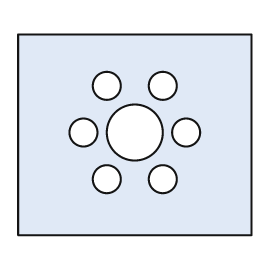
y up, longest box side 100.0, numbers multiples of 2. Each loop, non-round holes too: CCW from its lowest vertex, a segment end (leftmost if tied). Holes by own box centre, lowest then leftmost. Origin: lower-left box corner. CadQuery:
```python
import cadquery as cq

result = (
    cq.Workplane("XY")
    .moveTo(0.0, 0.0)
    .lineTo(100.0, 0.0)
    .lineTo(100.0, 86.0)
    .lineTo(0.0, 86.0)
    .close()
    .moveTo(38.0, 24.0)
    .circle(6.0)
    .moveTo(62.0, 24.0)
    .circle(6.0)
    .moveTo(28.0, 44.0)
    .circle(6.0)
    .moveTo(50.0, 44.0)
    .circle(12.0)
    .moveTo(72.0, 44.0)
    .circle(6.0)
    .moveTo(38.0, 64.0)
    .circle(6.0)
    .moveTo(62.0, 64.0)
    .circle(6.0)
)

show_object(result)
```